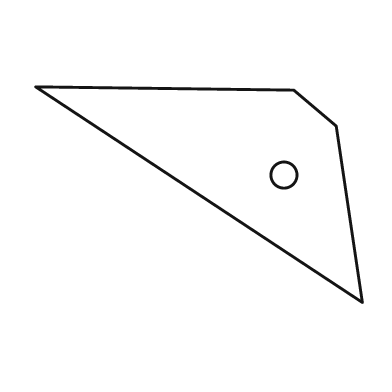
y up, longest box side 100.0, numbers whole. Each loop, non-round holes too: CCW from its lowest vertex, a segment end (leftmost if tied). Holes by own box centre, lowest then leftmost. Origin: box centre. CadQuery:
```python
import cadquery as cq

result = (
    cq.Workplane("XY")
    .moveTo(50.0, -33.0)
    .lineTo(42.0, 21.0)
    .lineTo(29.0, 32.0)
    .lineTo(-50.0, 33.0)
    .close()
    .moveTo(26.0, 6.0)
    .circle(4.0)
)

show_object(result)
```